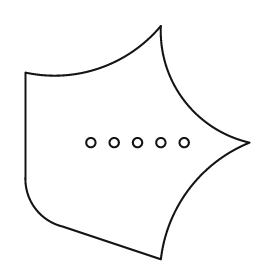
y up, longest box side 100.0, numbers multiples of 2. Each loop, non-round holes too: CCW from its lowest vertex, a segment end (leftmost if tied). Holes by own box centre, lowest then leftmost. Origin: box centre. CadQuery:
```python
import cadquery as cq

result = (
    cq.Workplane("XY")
    .moveTo(10.0, -50.0)
    .threePointArc((22.0, -20.0), (48.0, 0.0))
    .threePointArc((20.0, 18.0), (10.0, 50.0))
    .threePointArc((-16.0, 32.0), (-48.0, 30.0))
    .lineTo(-48.0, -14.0)
    .threePointArc((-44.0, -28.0), (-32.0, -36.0))
    .close()
    .moveTo(-20.0, 0.0)
    .circle(2.0)
    .moveTo(-10.0, 0.0)
    .circle(2.0)
    .moveTo(0.0, 0.0)
    .circle(2.0)
    .moveTo(10.0, 0.0)
    .circle(2.0)
    .moveTo(20.0, 0.0)
    .circle(2.0)
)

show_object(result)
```